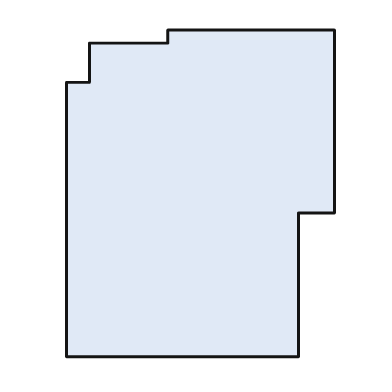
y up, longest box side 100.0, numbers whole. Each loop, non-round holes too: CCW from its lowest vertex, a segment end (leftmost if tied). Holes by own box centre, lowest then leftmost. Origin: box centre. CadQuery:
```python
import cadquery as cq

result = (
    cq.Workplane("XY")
    .moveTo(-41.0, -50.0)
    .lineTo(30.0, -50.0)
    .lineTo(30.0, -6.0)
    .lineTo(41.0, -6.0)
    .lineTo(41.0, 50.0)
    .lineTo(-10.0, 50.0)
    .lineTo(-10.0, 46.0)
    .lineTo(-34.0, 46.0)
    .lineTo(-34.0, 34.0)
    .lineTo(-41.0, 34.0)
    .close()
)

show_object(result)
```